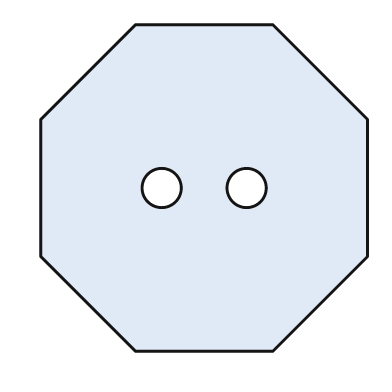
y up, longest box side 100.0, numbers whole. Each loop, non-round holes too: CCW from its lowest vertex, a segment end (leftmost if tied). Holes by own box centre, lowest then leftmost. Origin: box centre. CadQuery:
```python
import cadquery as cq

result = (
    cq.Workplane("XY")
    .moveTo(-21.0, -50.0)
    .lineTo(21.0, -50.0)
    .lineTo(50.0, -21.0)
    .lineTo(50.0, 21.0)
    .lineTo(21.0, 50.0)
    .lineTo(-21.0, 50.0)
    .lineTo(-50.0, 21.0)
    .lineTo(-50.0, -21.0)
    .close()
    .moveTo(-13.0, 0.0)
    .circle(6.0)
    .moveTo(13.0, 0.0)
    .circle(6.0)
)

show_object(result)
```